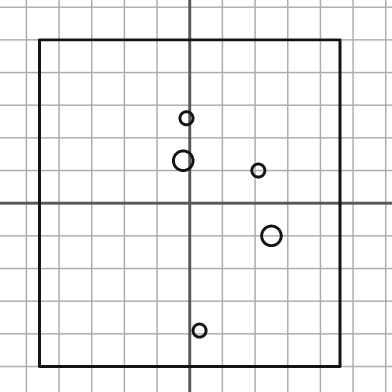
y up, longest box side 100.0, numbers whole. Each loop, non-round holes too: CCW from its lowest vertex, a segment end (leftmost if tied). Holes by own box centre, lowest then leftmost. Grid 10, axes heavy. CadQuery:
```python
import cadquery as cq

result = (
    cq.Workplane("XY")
    .moveTo(-46.0, -50.0)
    .lineTo(46.0, -50.0)
    .lineTo(46.0, 50.0)
    .lineTo(-46.0, 50.0)
    .close()
    .moveTo(3.0, -39.0)
    .circle(2.0)
    .moveTo(25.0, -10.0)
    .circle(3.0)
    .moveTo(21.0, 10.0)
    .circle(2.0)
    .moveTo(-2.0, 13.0)
    .circle(3.0)
    .moveTo(-1.0, 26.0)
    .circle(2.0)
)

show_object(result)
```